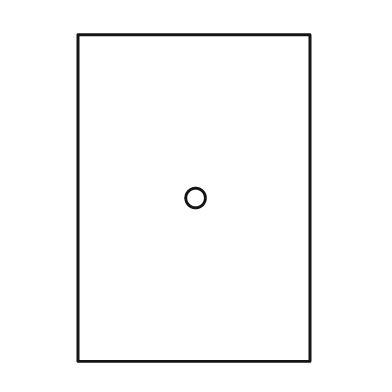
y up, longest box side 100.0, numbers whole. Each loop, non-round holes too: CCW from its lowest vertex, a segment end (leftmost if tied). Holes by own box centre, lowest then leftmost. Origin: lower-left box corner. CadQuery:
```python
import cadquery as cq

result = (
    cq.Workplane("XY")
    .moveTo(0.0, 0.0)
    .lineTo(71.0, 0.0)
    .lineTo(71.0, 100.0)
    .lineTo(0.0, 100.0)
    .close()
    .moveTo(36.0, 50.0)
    .circle(3.0)
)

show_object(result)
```